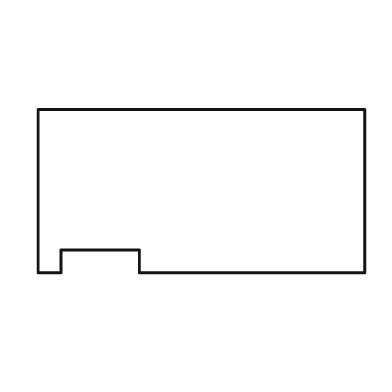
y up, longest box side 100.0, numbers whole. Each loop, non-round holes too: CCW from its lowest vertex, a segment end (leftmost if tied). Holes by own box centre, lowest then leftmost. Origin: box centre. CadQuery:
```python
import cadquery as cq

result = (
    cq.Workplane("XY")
    .moveTo(-50.0, -25.0)
    .lineTo(-43.0, -25.0)
    .lineTo(-43.0, -18.0)
    .lineTo(-19.0, -18.0)
    .lineTo(-19.0, -25.0)
    .lineTo(50.0, -25.0)
    .lineTo(50.0, 25.0)
    .lineTo(-50.0, 25.0)
    .close()
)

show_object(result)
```